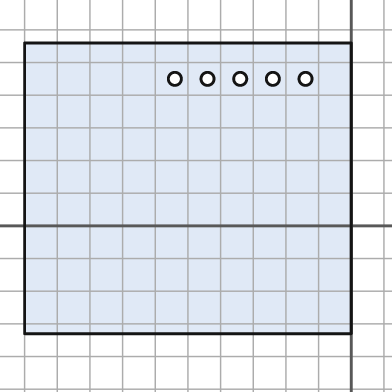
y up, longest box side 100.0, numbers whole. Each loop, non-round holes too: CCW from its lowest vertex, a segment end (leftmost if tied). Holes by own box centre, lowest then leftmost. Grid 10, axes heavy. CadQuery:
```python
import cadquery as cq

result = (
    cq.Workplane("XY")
    .moveTo(-100.0, -33.0)
    .lineTo(0.0, -33.0)
    .lineTo(0.0, 56.0)
    .lineTo(-100.0, 56.0)
    .close()
    .moveTo(-54.0, 45.0)
    .circle(2.0)
    .moveTo(-44.0, 45.0)
    .circle(2.0)
    .moveTo(-34.0, 45.0)
    .circle(2.0)
    .moveTo(-24.0, 45.0)
    .circle(2.0)
    .moveTo(-14.0, 45.0)
    .circle(2.0)
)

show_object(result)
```